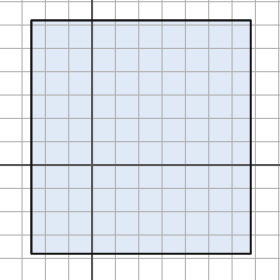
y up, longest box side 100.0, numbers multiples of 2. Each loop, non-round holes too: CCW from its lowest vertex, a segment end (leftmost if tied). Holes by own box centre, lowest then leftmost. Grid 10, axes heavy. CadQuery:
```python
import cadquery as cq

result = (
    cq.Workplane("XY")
    .moveTo(-26.0, -38.0)
    .lineTo(68.0, -38.0)
    .lineTo(68.0, 62.0)
    .lineTo(-26.0, 62.0)
    .close()
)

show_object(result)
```